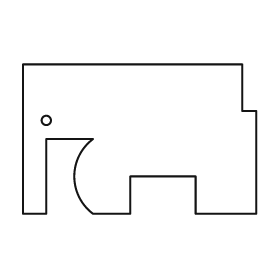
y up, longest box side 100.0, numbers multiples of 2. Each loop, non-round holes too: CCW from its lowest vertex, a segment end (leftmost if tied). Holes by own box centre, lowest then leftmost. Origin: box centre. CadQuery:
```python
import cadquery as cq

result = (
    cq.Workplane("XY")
    .moveTo(-50.0, -32.0)
    .lineTo(-40.0, -32.0)
    .lineTo(-40.0, 0.0)
    .lineTo(-20.0, 0.0)
    .threePointArc((-28.0, -16.0), (-20.0, -32.0))
    .lineTo(-4.0, -32.0)
    .lineTo(-4.0, -16.0)
    .lineTo(24.0, -16.0)
    .lineTo(24.0, -32.0)
    .lineTo(50.0, -32.0)
    .lineTo(50.0, 12.0)
    .lineTo(44.0, 12.0)
    .lineTo(44.0, 32.0)
    .lineTo(-50.0, 32.0)
    .close()
    .moveTo(-40.0, 8.0)
    .circle(2.0)
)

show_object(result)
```